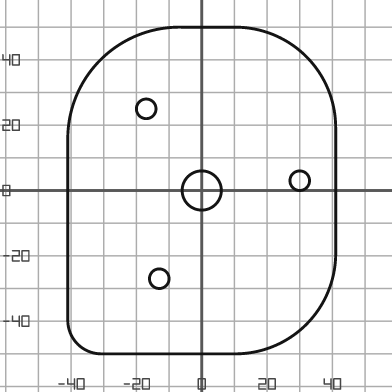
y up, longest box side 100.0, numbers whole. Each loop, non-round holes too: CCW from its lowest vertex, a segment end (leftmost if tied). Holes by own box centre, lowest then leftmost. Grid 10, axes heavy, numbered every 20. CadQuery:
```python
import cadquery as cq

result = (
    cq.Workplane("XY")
    .moveTo(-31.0, -50.0)
    .lineTo(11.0, -50.0)
    .threePointArc((32.0, -41.0), (41.0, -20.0))
    .lineTo(41.0, 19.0)
    .threePointArc((32.0, 41.0), (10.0, 50.0))
    .lineTo(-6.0, 50.0)
    .threePointArc((-31.0, 40.0), (-41.0, 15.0))
    .lineTo(-41.0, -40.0)
    .threePointArc((-38.0, -47.0), (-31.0, -50.0))
    .close()
    .moveTo(-13.0, -27.0)
    .circle(3.0)
    .moveTo(0.0, 0.0)
    .circle(6.0)
    .moveTo(30.0, 3.0)
    .circle(3.0)
    .moveTo(-17.0, 25.0)
    .circle(3.0)
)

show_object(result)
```